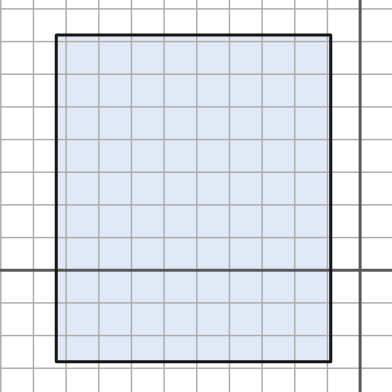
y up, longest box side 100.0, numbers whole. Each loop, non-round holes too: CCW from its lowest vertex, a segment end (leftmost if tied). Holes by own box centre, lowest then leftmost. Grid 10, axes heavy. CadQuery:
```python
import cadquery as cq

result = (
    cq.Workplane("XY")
    .moveTo(-93.0, -28.0)
    .lineTo(-9.0, -28.0)
    .lineTo(-9.0, 72.0)
    .lineTo(-93.0, 72.0)
    .close()
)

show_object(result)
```